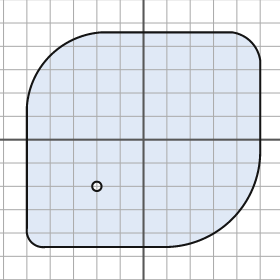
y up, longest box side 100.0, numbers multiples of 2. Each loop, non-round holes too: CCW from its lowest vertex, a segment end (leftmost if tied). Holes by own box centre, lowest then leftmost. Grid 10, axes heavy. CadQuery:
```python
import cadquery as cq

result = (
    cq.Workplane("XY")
    .moveTo(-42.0, -46.0)
    .lineTo(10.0, -46.0)
    .threePointArc((38.0, -34.0), (50.0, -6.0))
    .lineTo(50.0, 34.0)
    .threePointArc((46.0, 42.0), (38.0, 46.0))
    .lineTo(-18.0, 46.0)
    .threePointArc((-40.0, 36.0), (-50.0, 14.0))
    .lineTo(-50.0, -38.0)
    .threePointArc((-48.0, -44.0), (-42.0, -46.0))
    .close()
    .moveTo(-20.0, -20.0)
    .circle(2.0)
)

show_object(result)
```